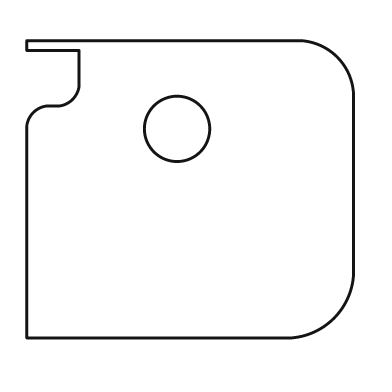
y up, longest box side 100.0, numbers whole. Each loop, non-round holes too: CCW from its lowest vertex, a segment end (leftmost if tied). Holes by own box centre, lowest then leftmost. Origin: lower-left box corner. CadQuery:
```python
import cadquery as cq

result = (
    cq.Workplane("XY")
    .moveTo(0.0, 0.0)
    .lineTo(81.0, 0.0)
    .threePointArc((94.0, 6.0), (100.0, 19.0))
    .lineTo(100.0, 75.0)
    .threePointArc((95.0, 86.0), (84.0, 91.0))
    .lineTo(0.0, 91.0)
    .lineTo(0.0, 88.0)
    .lineTo(16.0, 88.0)
    .lineTo(16.0, 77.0)
    .threePointArc((14.0, 73.0), (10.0, 71.0))
    .lineTo(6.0, 71.0)
    .threePointArc((2.0, 69.0), (0.0, 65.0))
    .close()
    .moveTo(46.0, 64.0)
    .circle(10.0)
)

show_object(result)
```